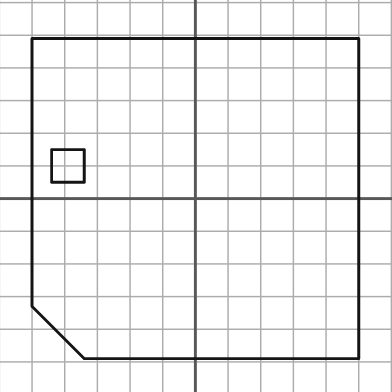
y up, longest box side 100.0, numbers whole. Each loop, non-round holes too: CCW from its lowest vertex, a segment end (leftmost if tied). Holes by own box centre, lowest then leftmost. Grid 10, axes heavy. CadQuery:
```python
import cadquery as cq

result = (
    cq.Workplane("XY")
    .moveTo(-34.0, -49.0)
    .lineTo(50.0, -49.0)
    .lineTo(50.0, 49.0)
    .lineTo(-50.0, 49.0)
    .lineTo(-50.0, -33.0)
    .close()
    .moveTo(-44.0, 5.0)
    .lineTo(-34.0, 5.0)
    .lineTo(-34.0, 15.0)
    .lineTo(-44.0, 15.0)
    .close()
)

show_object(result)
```